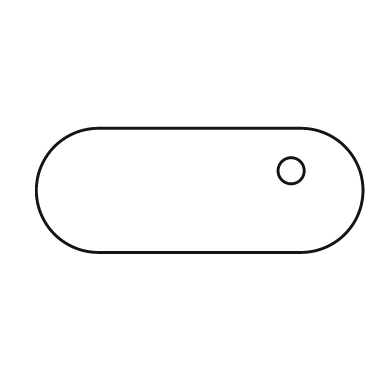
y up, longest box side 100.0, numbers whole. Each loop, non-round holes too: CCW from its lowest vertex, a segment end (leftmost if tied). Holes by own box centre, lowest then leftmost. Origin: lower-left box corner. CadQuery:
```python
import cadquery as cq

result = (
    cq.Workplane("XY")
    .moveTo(19.0, 0.0)
    .lineTo(81.0, 0.0)
    .threePointArc((100.0, 19.0), (81.0, 38.0))
    .lineTo(19.0, 38.0)
    .threePointArc((0.0, 19.0), (19.0, 0.0))
    .close()
    .moveTo(78.0, 25.0)
    .circle(4.0)
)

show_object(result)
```